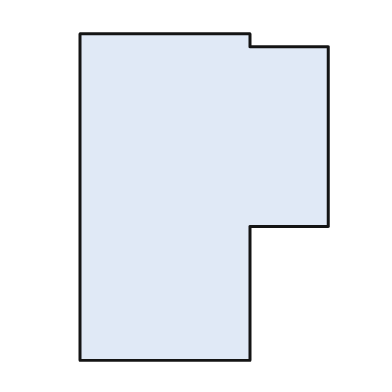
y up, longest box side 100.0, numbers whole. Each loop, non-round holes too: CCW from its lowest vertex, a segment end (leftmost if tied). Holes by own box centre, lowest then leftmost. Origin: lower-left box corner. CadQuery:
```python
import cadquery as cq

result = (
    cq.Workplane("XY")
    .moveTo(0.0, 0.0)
    .lineTo(52.0, 0.0)
    .lineTo(52.0, 41.0)
    .lineTo(76.0, 41.0)
    .lineTo(76.0, 96.0)
    .lineTo(52.0, 96.0)
    .lineTo(52.0, 100.0)
    .lineTo(0.0, 100.0)
    .close()
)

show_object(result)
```